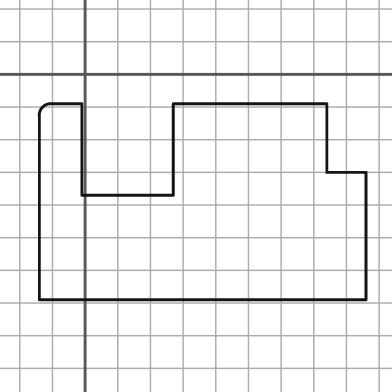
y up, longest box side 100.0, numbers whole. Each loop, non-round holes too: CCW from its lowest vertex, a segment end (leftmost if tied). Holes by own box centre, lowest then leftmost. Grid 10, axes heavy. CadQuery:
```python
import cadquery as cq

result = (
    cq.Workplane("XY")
    .moveTo(-14.0, -69.0)
    .lineTo(86.0, -69.0)
    .lineTo(86.0, -30.0)
    .lineTo(74.0, -30.0)
    .lineTo(74.0, -9.0)
    .lineTo(27.0, -9.0)
    .lineTo(27.0, -37.0)
    .lineTo(-1.0, -37.0)
    .lineTo(-1.0, -9.0)
    .lineTo(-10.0, -9.0)
    .threePointArc((-13.0, -10.0), (-14.0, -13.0))
    .close()
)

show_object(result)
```